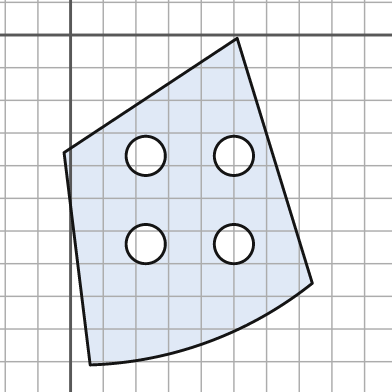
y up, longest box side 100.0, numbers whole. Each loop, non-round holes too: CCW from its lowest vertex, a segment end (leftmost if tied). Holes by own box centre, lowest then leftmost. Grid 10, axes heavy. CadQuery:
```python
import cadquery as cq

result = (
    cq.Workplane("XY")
    .moveTo(6.0, -101.0)
    .threePointArc((42.0, -94.0), (74.0, -76.0))
    .lineTo(51.0, -1.0)
    .lineTo(-2.0, -36.0)
    .close()
    .moveTo(23.0, -64.0)
    .circle(6.0)
    .moveTo(50.0, -64.0)
    .circle(6.0)
    .moveTo(23.0, -37.0)
    .circle(6.0)
    .moveTo(50.0, -37.0)
    .circle(6.0)
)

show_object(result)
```